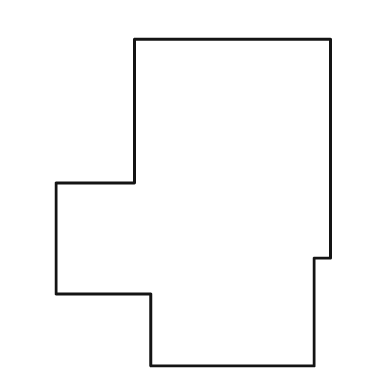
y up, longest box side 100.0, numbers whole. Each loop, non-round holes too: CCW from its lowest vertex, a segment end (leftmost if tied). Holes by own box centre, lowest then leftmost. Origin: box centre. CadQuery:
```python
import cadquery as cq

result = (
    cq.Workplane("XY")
    .moveTo(-13.0, -50.0)
    .lineTo(37.0, -50.0)
    .lineTo(37.0, -17.0)
    .lineTo(42.0, -17.0)
    .lineTo(42.0, 50.0)
    .lineTo(-18.0, 50.0)
    .lineTo(-18.0, 6.0)
    .lineTo(-42.0, 6.0)
    .lineTo(-42.0, -28.0)
    .lineTo(-13.0, -28.0)
    .close()
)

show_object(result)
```